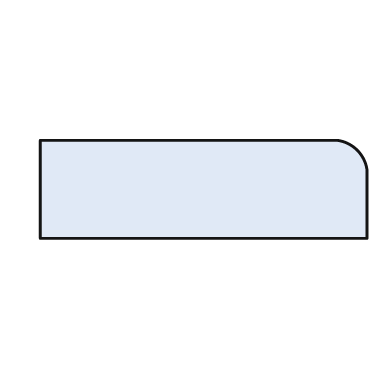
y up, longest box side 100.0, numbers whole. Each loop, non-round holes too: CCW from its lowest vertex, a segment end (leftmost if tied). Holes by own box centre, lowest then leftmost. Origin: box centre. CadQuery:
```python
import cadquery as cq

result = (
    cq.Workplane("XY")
    .moveTo(-50.0, -15.0)
    .lineTo(50.0, -15.0)
    .lineTo(50.0, 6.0)
    .threePointArc((47.0, 12.0), (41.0, 15.0))
    .lineTo(-50.0, 15.0)
    .close()
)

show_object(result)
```